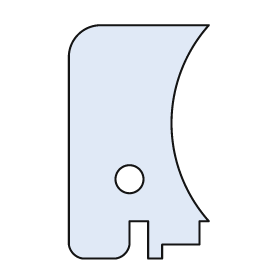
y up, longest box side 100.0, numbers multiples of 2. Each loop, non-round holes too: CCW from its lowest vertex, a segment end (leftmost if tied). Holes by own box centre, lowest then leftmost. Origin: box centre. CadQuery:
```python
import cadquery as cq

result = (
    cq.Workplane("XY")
    .moveTo(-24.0, -50.0)
    .lineTo(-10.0, -50.0)
    .threePointArc((-6.0, -48.0), (-4.0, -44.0))
    .lineTo(-4.0, -34.0)
    .lineTo(4.0, -34.0)
    .lineTo(4.0, -50.0)
    .lineTo(10.0, -50.0)
    .lineTo(10.0, -44.0)
    .lineTo(26.0, -44.0)
    .lineTo(26.0, -34.0)
    .lineTo(30.0, -34.0)
    .threePointArc((14.0, 8.0), (30.0, 50.0))
    .lineTo(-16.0, 50.0)
    .threePointArc((-26.0, 46.0), (-30.0, 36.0))
    .lineTo(-30.0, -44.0)
    .threePointArc((-28.0, -48.0), (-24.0, -50.0))
    .close()
    .moveTo(-4.0, -16.0)
    .circle(6.0)
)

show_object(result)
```